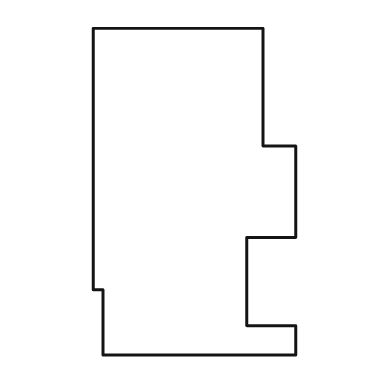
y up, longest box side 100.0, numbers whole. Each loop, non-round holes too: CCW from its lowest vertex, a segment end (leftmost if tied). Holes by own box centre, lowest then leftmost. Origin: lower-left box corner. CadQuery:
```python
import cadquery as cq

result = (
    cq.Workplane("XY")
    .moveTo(3.0, 0.0)
    .lineTo(62.0, 0.0)
    .lineTo(62.0, 9.0)
    .lineTo(47.0, 9.0)
    .lineTo(47.0, 36.0)
    .lineTo(62.0, 36.0)
    .lineTo(62.0, 64.0)
    .lineTo(52.0, 64.0)
    .lineTo(52.0, 100.0)
    .lineTo(0.0, 100.0)
    .lineTo(0.0, 20.0)
    .lineTo(3.0, 20.0)
    .close()
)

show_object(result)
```